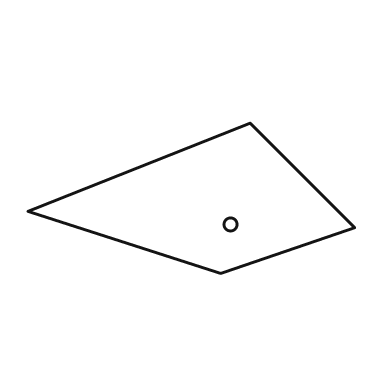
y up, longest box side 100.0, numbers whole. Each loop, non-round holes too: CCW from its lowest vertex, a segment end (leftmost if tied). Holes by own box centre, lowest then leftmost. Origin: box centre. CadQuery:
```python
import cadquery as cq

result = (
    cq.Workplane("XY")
    .moveTo(9.0, -23.0)
    .lineTo(50.0, -9.0)
    .lineTo(18.0, 23.0)
    .lineTo(-50.0, -4.0)
    .close()
    .moveTo(12.0, -8.0)
    .circle(2.0)
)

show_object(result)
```